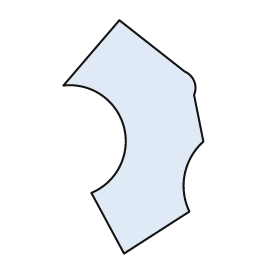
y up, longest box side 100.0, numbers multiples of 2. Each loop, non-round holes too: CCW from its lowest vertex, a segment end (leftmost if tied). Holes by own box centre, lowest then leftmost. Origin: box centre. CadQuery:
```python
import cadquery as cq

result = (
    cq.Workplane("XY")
    .moveTo(-4.0, -50.0)
    .lineTo(24.0, -32.0)
    .threePointArc((22.0, -16.0), (30.0, -2.0))
    .lineTo(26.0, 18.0)
    .threePointArc((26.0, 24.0), (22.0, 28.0))
    .lineTo(-6.0, 50.0)
    .lineTo(-30.0, 22.0)
    .threePointArc((-4.0, 4.0), (-18.0, -24.0))
    .close()
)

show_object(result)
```